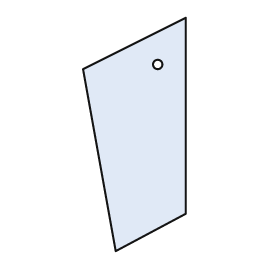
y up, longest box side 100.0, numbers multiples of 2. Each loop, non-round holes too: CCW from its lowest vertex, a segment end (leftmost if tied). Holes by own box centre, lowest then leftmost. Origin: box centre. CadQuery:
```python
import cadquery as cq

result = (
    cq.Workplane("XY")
    .moveTo(-8.0, -50.0)
    .lineTo(22.0, -34.0)
    .lineTo(22.0, 50.0)
    .lineTo(-22.0, 28.0)
    .close()
    .moveTo(10.0, 30.0)
    .circle(2.0)
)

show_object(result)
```